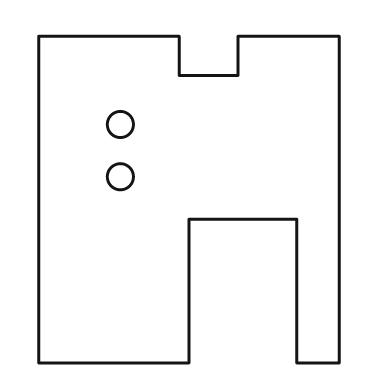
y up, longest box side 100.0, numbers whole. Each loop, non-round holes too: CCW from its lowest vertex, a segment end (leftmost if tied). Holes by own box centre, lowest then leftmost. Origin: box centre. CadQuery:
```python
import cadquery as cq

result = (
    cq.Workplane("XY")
    .moveTo(-46.0, -50.0)
    .lineTo(0.0, -50.0)
    .lineTo(0.0, -6.0)
    .lineTo(33.0, -6.0)
    .lineTo(33.0, -50.0)
    .lineTo(46.0, -50.0)
    .lineTo(46.0, 50.0)
    .lineTo(15.0, 50.0)
    .lineTo(15.0, 38.0)
    .lineTo(-3.0, 38.0)
    .lineTo(-3.0, 50.0)
    .lineTo(-46.0, 50.0)
    .close()
    .moveTo(-21.0, 7.0)
    .circle(4.0)
    .moveTo(-21.0, 23.0)
    .circle(4.0)
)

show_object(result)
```